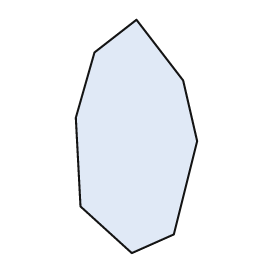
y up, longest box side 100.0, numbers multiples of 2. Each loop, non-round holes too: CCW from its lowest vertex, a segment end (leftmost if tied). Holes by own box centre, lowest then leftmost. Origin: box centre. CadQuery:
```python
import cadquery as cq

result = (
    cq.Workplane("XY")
    .moveTo(-2.0, -50.0)
    .lineTo(16.0, -42.0)
    .lineTo(26.0, -2.0)
    .lineTo(20.0, 24.0)
    .lineTo(0.0, 50.0)
    .lineTo(-18.0, 36.0)
    .lineTo(-26.0, 8.0)
    .lineTo(-24.0, -30.0)
    .close()
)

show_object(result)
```